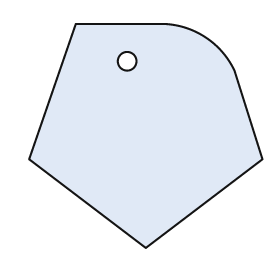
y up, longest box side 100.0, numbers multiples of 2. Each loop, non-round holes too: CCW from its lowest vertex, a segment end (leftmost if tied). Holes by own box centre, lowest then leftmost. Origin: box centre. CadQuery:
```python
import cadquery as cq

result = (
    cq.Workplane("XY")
    .moveTo(0.0, -48.0)
    .lineTo(50.0, -10.0)
    .lineTo(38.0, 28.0)
    .threePointArc((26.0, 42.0), (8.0, 48.0))
    .lineTo(-30.0, 48.0)
    .lineTo(-50.0, -10.0)
    .close()
    .moveTo(-8.0, 32.0)
    .circle(4.0)
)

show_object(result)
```